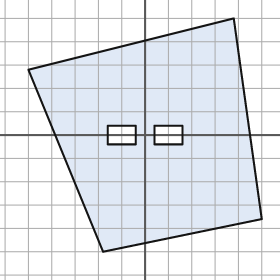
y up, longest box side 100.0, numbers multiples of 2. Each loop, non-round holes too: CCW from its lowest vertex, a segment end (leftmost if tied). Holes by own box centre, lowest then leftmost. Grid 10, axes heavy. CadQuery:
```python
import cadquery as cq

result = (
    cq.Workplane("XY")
    .moveTo(-18.0, -50.0)
    .lineTo(50.0, -36.0)
    .lineTo(38.0, 50.0)
    .lineTo(-50.0, 28.0)
    .close()
    .moveTo(-16.0, -4.0)
    .lineTo(-4.0, -4.0)
    .lineTo(-4.0, 4.0)
    .lineTo(-16.0, 4.0)
    .close()
    .moveTo(4.0, -4.0)
    .lineTo(16.0, -4.0)
    .lineTo(16.0, 4.0)
    .lineTo(4.0, 4.0)
    .close()
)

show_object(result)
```